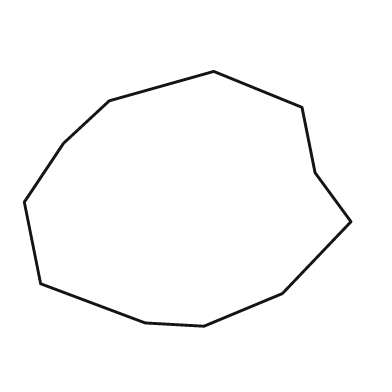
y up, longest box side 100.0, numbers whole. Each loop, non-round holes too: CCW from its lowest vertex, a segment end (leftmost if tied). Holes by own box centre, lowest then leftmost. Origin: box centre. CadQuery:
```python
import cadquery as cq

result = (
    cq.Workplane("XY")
    .moveTo(5.0, -39.0)
    .lineTo(29.0, -29.0)
    .lineTo(50.0, -7.0)
    .lineTo(39.0, 8.0)
    .lineTo(35.0, 28.0)
    .lineTo(8.0, 39.0)
    .lineTo(-24.0, 30.0)
    .lineTo(-38.0, 17.0)
    .lineTo(-50.0, -1.0)
    .lineTo(-45.0, -26.0)
    .lineTo(-13.0, -38.0)
    .close()
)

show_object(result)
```